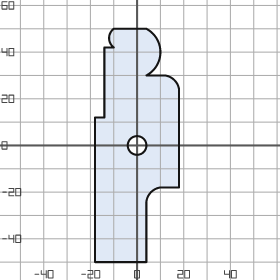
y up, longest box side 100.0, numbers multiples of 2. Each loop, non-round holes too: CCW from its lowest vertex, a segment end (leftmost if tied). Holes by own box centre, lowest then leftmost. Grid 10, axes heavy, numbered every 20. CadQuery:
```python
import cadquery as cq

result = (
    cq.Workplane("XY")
    .moveTo(-18.0, -50.0)
    .lineTo(4.0, -50.0)
    .lineTo(4.0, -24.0)
    .threePointArc((6.0, -20.0), (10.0, -18.0))
    .lineTo(18.0, -18.0)
    .lineTo(18.0, 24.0)
    .threePointArc((16.0, 28.0), (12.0, 30.0))
    .lineTo(4.0, 30.0)
    .threePointArc((10.0, 40.0), (4.0, 50.0))
    .lineTo(-10.0, 50.0)
    .threePointArc((-12.0, 46.0), (-10.0, 42.0))
    .lineTo(-14.0, 42.0)
    .lineTo(-14.0, 12.0)
    .lineTo(-18.0, 12.0)
    .close()
    .moveTo(0.0, 0.0)
    .circle(4.0)
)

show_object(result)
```